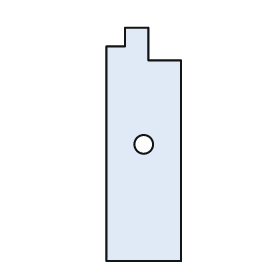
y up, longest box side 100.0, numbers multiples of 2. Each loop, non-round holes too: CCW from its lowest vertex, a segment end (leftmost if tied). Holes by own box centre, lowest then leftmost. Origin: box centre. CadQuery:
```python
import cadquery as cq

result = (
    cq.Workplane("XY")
    .moveTo(-16.0, -50.0)
    .lineTo(16.0, -50.0)
    .lineTo(16.0, 36.0)
    .lineTo(2.0, 36.0)
    .lineTo(2.0, 50.0)
    .lineTo(-8.0, 50.0)
    .lineTo(-8.0, 42.0)
    .lineTo(-16.0, 42.0)
    .close()
    .moveTo(0.0, 0.0)
    .circle(4.0)
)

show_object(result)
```